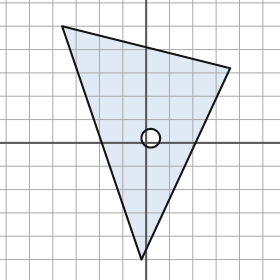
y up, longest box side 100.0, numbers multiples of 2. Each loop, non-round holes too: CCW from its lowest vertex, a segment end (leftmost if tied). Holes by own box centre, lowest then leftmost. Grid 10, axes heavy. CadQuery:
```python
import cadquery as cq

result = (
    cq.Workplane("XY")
    .moveTo(-2.0, -50.0)
    .lineTo(36.0, 32.0)
    .lineTo(-36.0, 50.0)
    .close()
    .moveTo(2.0, 2.0)
    .circle(4.0)
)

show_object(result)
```